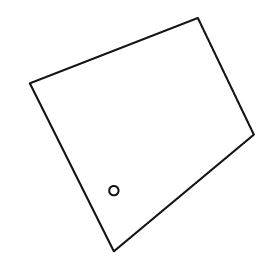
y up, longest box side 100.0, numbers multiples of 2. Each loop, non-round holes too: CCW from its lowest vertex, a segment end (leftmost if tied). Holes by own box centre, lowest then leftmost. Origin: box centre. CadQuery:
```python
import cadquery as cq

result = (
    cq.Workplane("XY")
    .moveTo(-12.0, -50.0)
    .lineTo(48.0, 0.0)
    .lineTo(24.0, 50.0)
    .lineTo(-48.0, 22.0)
    .close()
    .moveTo(-12.0, -24.0)
    .circle(2.0)
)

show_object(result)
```